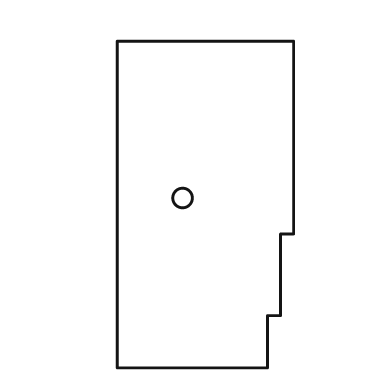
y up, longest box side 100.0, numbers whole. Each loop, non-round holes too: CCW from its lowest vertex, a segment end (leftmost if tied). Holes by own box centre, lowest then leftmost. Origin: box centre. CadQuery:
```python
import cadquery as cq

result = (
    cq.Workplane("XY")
    .moveTo(-27.0, -50.0)
    .lineTo(19.0, -50.0)
    .lineTo(19.0, -34.0)
    .lineTo(23.0, -34.0)
    .lineTo(23.0, -9.0)
    .lineTo(27.0, -9.0)
    .lineTo(27.0, 50.0)
    .lineTo(-27.0, 50.0)
    .close()
    .moveTo(-7.0, 2.0)
    .circle(3.0)
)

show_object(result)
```